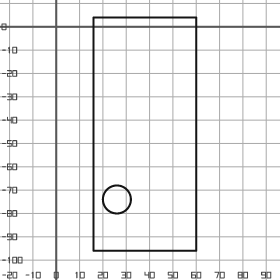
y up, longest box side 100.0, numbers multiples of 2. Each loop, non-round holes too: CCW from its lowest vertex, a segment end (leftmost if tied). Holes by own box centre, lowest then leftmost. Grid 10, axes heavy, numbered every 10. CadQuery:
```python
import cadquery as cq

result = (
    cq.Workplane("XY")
    .moveTo(16.0, -96.0)
    .lineTo(60.0, -96.0)
    .lineTo(60.0, 4.0)
    .lineTo(16.0, 4.0)
    .close()
    .moveTo(26.0, -74.0)
    .circle(6.0)
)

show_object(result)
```